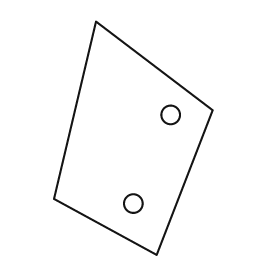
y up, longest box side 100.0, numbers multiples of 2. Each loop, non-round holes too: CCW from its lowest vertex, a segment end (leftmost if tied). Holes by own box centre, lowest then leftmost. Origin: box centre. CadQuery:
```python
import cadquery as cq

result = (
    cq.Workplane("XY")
    .moveTo(10.0, -50.0)
    .lineTo(34.0, 12.0)
    .lineTo(-16.0, 50.0)
    .lineTo(-34.0, -26.0)
    .close()
    .moveTo(0.0, -28.0)
    .circle(4.0)
    .moveTo(16.0, 10.0)
    .circle(4.0)
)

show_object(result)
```